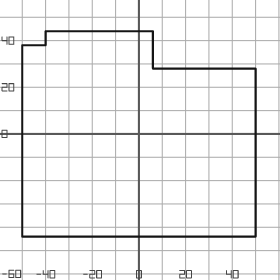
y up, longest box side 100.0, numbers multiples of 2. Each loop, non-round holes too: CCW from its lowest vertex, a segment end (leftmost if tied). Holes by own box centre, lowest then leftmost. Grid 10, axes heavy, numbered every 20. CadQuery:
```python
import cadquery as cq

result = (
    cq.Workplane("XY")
    .moveTo(-50.0, -44.0)
    .lineTo(50.0, -44.0)
    .lineTo(50.0, 28.0)
    .lineTo(6.0, 28.0)
    .lineTo(6.0, 44.0)
    .lineTo(-40.0, 44.0)
    .lineTo(-40.0, 38.0)
    .lineTo(-50.0, 38.0)
    .close()
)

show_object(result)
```